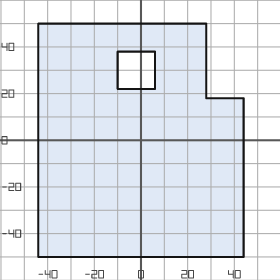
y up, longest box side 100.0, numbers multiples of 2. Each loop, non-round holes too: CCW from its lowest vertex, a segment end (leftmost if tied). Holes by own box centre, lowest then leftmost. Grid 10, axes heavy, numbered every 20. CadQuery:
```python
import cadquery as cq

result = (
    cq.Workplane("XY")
    .moveTo(-44.0, -50.0)
    .lineTo(44.0, -50.0)
    .lineTo(44.0, 18.0)
    .lineTo(28.0, 18.0)
    .lineTo(28.0, 50.0)
    .lineTo(-44.0, 50.0)
    .close()
    .moveTo(-10.0, 22.0)
    .lineTo(6.0, 22.0)
    .lineTo(6.0, 38.0)
    .lineTo(-10.0, 38.0)
    .close()
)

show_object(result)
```